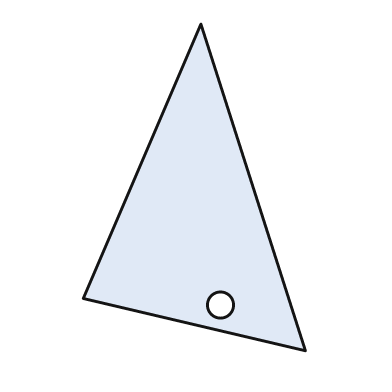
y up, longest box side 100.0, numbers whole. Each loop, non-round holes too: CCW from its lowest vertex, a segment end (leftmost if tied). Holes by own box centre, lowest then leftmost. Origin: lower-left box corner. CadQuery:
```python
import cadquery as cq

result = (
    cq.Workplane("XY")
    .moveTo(68.0, 0.0)
    .lineTo(36.0, 100.0)
    .lineTo(0.0, 16.0)
    .close()
    .moveTo(42.0, 14.0)
    .circle(4.0)
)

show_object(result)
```